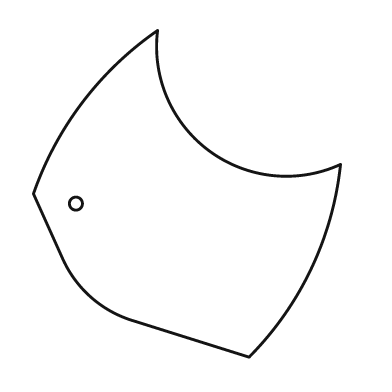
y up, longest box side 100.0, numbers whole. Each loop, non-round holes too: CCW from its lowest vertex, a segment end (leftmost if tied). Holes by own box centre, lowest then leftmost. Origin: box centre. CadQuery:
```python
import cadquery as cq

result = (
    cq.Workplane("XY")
    .moveTo(19.0, -50.0)
    .threePointArc((38.0, -23.0), (47.0, 9.0))
    .threePointArc((7.0, 13.0), (-9.0, 50.0))
    .threePointArc((-32.0, 28.0), (-47.0, 0.0))
    .lineTo(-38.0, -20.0)
    .threePointArc((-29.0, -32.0), (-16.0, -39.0))
    .close()
    .moveTo(-34.0, -3.0)
    .circle(2.0)
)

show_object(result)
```